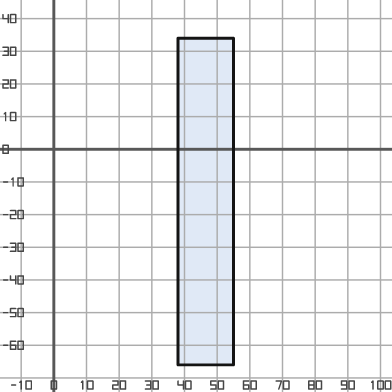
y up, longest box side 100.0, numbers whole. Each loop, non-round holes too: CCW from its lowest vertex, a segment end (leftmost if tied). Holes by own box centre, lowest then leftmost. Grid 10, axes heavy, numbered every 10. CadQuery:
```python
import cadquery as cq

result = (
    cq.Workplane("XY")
    .moveTo(38.0, -66.0)
    .lineTo(55.0, -66.0)
    .lineTo(55.0, 34.0)
    .lineTo(38.0, 34.0)
    .close()
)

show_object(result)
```